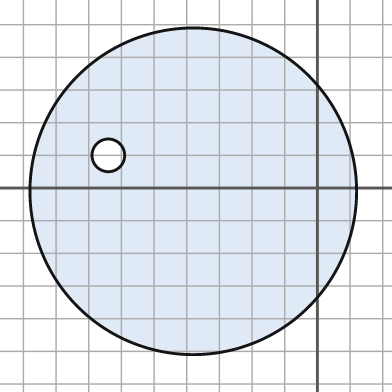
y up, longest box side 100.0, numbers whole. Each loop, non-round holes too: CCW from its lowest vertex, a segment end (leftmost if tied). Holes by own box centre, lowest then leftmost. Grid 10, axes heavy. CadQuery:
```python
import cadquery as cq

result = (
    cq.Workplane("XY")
    .moveTo(-38.0, -1.0)
    .circle(50.0)
    .moveTo(-64.0, 10.0)
    .circle(5.0)
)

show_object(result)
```